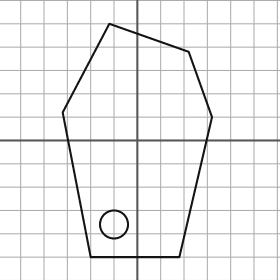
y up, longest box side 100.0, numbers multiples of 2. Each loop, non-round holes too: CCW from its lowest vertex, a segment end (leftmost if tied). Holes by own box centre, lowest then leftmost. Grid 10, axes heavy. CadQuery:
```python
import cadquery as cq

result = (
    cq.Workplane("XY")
    .moveTo(-20.0, -50.0)
    .lineTo(18.0, -50.0)
    .lineTo(32.0, 10.0)
    .lineTo(22.0, 38.0)
    .lineTo(-12.0, 50.0)
    .lineTo(-32.0, 12.0)
    .close()
    .moveTo(-10.0, -36.0)
    .circle(6.0)
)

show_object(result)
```